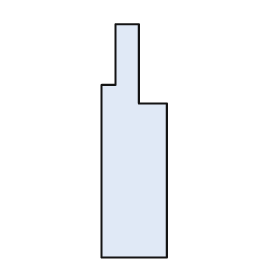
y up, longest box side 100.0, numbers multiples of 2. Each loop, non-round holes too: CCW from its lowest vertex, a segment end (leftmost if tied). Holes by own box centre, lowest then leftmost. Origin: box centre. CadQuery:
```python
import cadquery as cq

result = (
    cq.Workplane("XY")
    .moveTo(-14.0, -50.0)
    .lineTo(14.0, -50.0)
    .lineTo(14.0, 16.0)
    .lineTo(2.0, 16.0)
    .lineTo(2.0, 50.0)
    .lineTo(-8.0, 50.0)
    .lineTo(-8.0, 24.0)
    .lineTo(-14.0, 24.0)
    .close()
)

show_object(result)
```